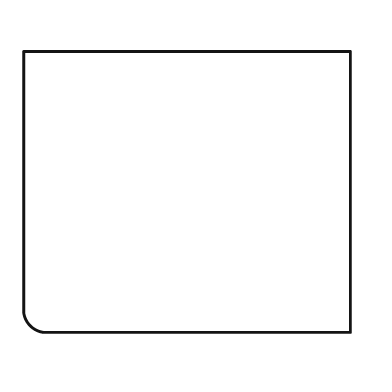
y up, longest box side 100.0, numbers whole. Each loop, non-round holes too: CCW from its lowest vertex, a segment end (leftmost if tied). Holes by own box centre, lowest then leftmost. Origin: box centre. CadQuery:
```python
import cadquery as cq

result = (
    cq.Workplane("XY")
    .moveTo(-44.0, -43.0)
    .lineTo(50.0, -43.0)
    .lineTo(50.0, 43.0)
    .lineTo(-50.0, 43.0)
    .lineTo(-50.0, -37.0)
    .threePointArc((-48.0, -41.0), (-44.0, -43.0))
    .close()
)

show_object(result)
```